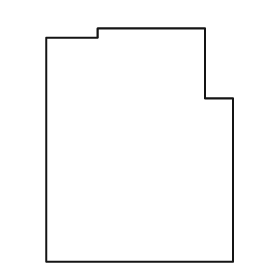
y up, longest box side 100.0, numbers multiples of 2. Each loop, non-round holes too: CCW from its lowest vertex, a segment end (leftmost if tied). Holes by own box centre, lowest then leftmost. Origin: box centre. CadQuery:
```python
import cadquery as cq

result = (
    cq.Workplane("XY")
    .moveTo(-40.0, -50.0)
    .lineTo(40.0, -50.0)
    .lineTo(40.0, 20.0)
    .lineTo(28.0, 20.0)
    .lineTo(28.0, 50.0)
    .lineTo(-18.0, 50.0)
    .lineTo(-18.0, 46.0)
    .lineTo(-40.0, 46.0)
    .close()
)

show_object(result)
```